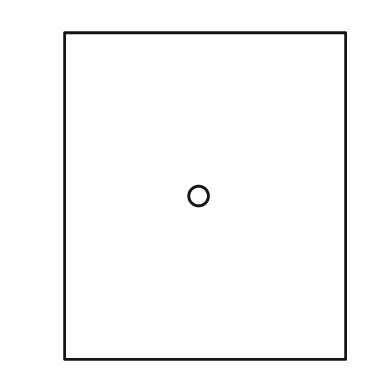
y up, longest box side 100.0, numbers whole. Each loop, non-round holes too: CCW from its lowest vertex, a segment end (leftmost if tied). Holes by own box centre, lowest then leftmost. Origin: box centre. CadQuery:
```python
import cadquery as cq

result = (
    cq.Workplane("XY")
    .moveTo(-43.0, -50.0)
    .lineTo(43.0, -50.0)
    .lineTo(43.0, 50.0)
    .lineTo(-43.0, 50.0)
    .close()
    .moveTo(-2.0, 0.0)
    .circle(3.0)
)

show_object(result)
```